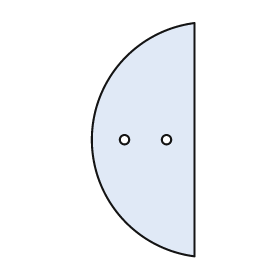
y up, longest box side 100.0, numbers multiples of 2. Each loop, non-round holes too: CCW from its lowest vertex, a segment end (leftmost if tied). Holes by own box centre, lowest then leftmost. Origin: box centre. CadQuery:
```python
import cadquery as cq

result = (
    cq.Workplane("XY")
    .moveTo(22.0, -50.0)
    .lineTo(22.0, 50.0)
    .threePointArc((-22.0, 0.0), (22.0, -50.0))
    .close()
    .moveTo(-8.0, 0.0)
    .circle(2.0)
    .moveTo(10.0, 0.0)
    .circle(2.0)
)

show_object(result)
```